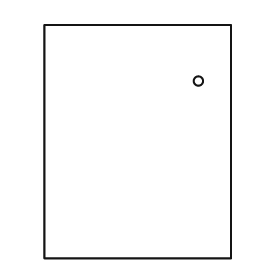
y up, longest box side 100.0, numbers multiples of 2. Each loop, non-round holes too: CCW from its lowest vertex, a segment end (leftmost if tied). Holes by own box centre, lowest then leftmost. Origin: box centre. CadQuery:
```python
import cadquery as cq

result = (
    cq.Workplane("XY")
    .moveTo(-40.0, -50.0)
    .lineTo(40.0, -50.0)
    .lineTo(40.0, 50.0)
    .lineTo(-40.0, 50.0)
    .close()
    .moveTo(26.0, 26.0)
    .circle(2.0)
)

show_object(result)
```